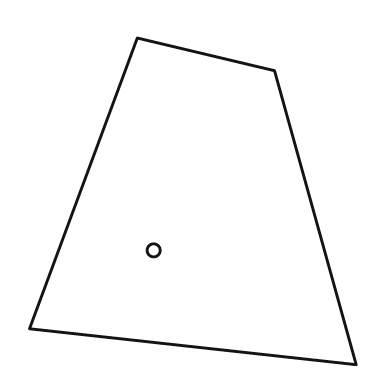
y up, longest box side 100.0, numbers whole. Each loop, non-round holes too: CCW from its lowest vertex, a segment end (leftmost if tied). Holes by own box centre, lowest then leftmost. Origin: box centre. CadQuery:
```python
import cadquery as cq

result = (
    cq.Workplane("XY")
    .moveTo(50.0, -50.0)
    .lineTo(25.0, 40.0)
    .lineTo(-17.0, 50.0)
    .lineTo(-50.0, -39.0)
    .close()
    .moveTo(-12.0, -15.0)
    .circle(2.0)
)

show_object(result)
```